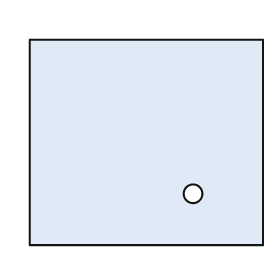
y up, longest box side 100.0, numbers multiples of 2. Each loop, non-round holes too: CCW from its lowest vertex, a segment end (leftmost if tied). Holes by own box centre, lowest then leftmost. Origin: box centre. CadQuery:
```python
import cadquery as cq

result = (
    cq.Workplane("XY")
    .moveTo(-50.0, -44.0)
    .lineTo(50.0, -44.0)
    .lineTo(50.0, 44.0)
    .lineTo(-50.0, 44.0)
    .close()
    .moveTo(20.0, -22.0)
    .circle(4.0)
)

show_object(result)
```